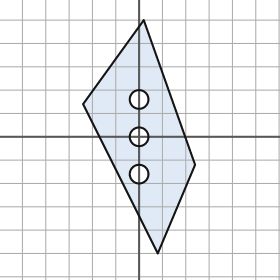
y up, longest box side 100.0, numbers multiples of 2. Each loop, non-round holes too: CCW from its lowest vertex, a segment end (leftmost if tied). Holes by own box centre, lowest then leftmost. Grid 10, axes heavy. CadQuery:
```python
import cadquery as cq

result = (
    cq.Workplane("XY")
    .moveTo(8.0, -50.0)
    .lineTo(24.0, -12.0)
    .lineTo(2.0, 50.0)
    .lineTo(-24.0, 14.0)
    .close()
    .moveTo(0.0, -16.0)
    .circle(4.0)
    .moveTo(0.0, 0.0)
    .circle(4.0)
    .moveTo(0.0, 16.0)
    .circle(4.0)
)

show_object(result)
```